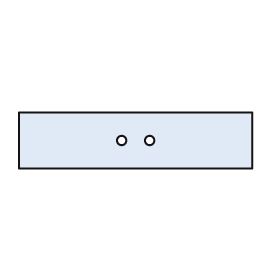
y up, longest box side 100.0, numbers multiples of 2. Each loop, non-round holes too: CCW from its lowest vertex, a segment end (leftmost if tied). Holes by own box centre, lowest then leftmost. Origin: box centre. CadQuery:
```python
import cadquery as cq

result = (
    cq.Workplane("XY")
    .moveTo(-50.0, -12.0)
    .lineTo(50.0, -12.0)
    .lineTo(50.0, 12.0)
    .lineTo(-50.0, 12.0)
    .close()
    .moveTo(-6.0, 0.0)
    .circle(2.0)
    .moveTo(6.0, 0.0)
    .circle(2.0)
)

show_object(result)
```